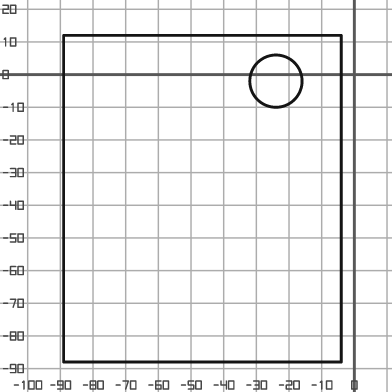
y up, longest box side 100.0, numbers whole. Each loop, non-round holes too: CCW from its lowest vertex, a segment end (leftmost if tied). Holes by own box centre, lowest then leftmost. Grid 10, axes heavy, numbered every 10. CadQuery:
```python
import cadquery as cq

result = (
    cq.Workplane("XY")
    .moveTo(-89.0, -88.0)
    .lineTo(-4.0, -88.0)
    .lineTo(-4.0, 12.0)
    .lineTo(-89.0, 12.0)
    .close()
    .moveTo(-24.0, -2.0)
    .circle(8.0)
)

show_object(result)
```